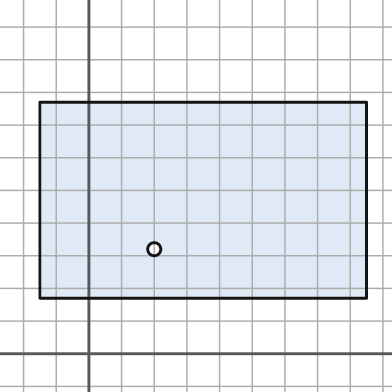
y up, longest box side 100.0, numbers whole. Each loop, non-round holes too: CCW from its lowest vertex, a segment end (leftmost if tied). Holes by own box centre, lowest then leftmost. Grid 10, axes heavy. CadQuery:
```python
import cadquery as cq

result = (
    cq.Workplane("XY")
    .moveTo(-15.0, 17.0)
    .lineTo(85.0, 17.0)
    .lineTo(85.0, 77.0)
    .lineTo(-15.0, 77.0)
    .close()
    .moveTo(20.0, 32.0)
    .circle(2.0)
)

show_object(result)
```